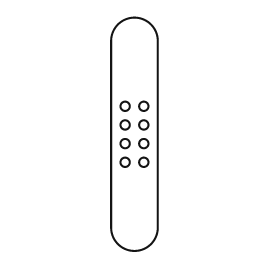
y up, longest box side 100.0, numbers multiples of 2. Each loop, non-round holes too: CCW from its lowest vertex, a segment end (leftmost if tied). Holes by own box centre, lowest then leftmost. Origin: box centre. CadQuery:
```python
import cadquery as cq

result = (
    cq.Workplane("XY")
    .moveTo(-10.0, -40.0)
    .threePointArc((0.0, -50.0), (10.0, -40.0))
    .lineTo(10.0, 40.0)
    .threePointArc((0.0, 50.0), (-10.0, 40.0))
    .close()
    .moveTo(-4.0, -12.0)
    .circle(2.0)
    .moveTo(4.0, -12.0)
    .circle(2.0)
    .moveTo(-4.0, -4.0)
    .circle(2.0)
    .moveTo(4.0, -4.0)
    .circle(2.0)
    .moveTo(-4.0, 4.0)
    .circle(2.0)
    .moveTo(4.0, 4.0)
    .circle(2.0)
    .moveTo(-4.0, 12.0)
    .circle(2.0)
    .moveTo(4.0, 12.0)
    .circle(2.0)
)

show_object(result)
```